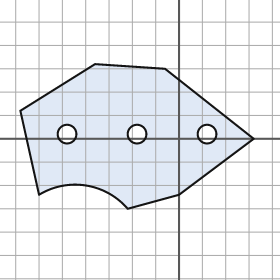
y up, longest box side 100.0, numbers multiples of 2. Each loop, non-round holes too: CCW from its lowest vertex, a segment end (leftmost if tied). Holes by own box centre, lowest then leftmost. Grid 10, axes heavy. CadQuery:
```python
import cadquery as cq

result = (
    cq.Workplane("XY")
    .moveTo(-22.0, -30.0)
    .lineTo(0.0, -24.0)
    .lineTo(32.0, 0.0)
    .lineTo(-6.0, 30.0)
    .lineTo(-36.0, 32.0)
    .lineTo(-68.0, 12.0)
    .lineTo(-60.0, -24.0)
    .threePointArc((-40.0, -20.0), (-22.0, -30.0))
    .close()
    .moveTo(-48.0, 2.0)
    .circle(4.0)
    .moveTo(-18.0, 2.0)
    .circle(4.0)
    .moveTo(12.0, 2.0)
    .circle(4.0)
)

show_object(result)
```